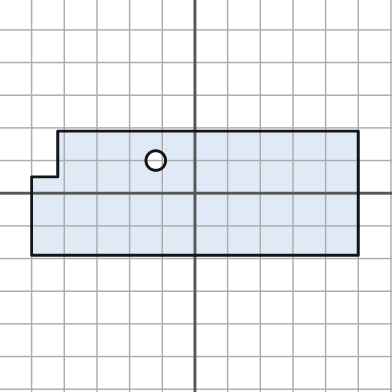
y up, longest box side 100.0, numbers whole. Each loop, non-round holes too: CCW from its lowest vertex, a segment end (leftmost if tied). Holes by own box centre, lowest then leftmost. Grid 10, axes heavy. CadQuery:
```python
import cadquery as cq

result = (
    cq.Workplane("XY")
    .moveTo(-50.0, -19.0)
    .lineTo(50.0, -19.0)
    .lineTo(50.0, 19.0)
    .lineTo(-42.0, 19.0)
    .lineTo(-42.0, 5.0)
    .lineTo(-50.0, 5.0)
    .close()
    .moveTo(-12.0, 10.0)
    .circle(3.0)
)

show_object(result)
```